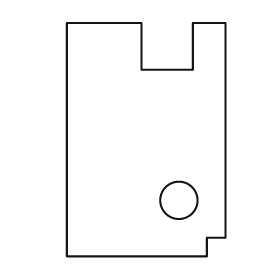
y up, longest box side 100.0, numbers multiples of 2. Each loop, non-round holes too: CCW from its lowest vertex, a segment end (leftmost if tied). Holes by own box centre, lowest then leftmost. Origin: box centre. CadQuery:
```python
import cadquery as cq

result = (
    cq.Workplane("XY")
    .moveTo(-34.0, -50.0)
    .lineTo(26.0, -50.0)
    .lineTo(26.0, -42.0)
    .lineTo(34.0, -42.0)
    .lineTo(34.0, 50.0)
    .lineTo(20.0, 50.0)
    .lineTo(20.0, 30.0)
    .lineTo(-2.0, 30.0)
    .lineTo(-2.0, 50.0)
    .lineTo(-34.0, 50.0)
    .close()
    .moveTo(14.0, -26.0)
    .circle(8.0)
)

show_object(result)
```